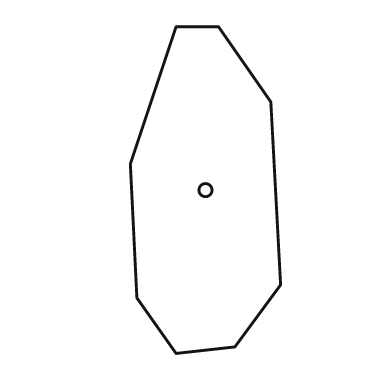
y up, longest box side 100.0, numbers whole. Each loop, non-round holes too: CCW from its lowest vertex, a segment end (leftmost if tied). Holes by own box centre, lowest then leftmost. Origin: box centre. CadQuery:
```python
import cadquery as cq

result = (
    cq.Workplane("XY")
    .moveTo(-9.0, -50.0)
    .lineTo(9.0, -48.0)
    .lineTo(23.0, -29.0)
    .lineTo(20.0, 27.0)
    .lineTo(4.0, 50.0)
    .lineTo(-9.0, 50.0)
    .lineTo(-23.0, 8.0)
    .lineTo(-21.0, -33.0)
    .close()
    .moveTo(0.0, 0.0)
    .circle(2.0)
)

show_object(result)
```